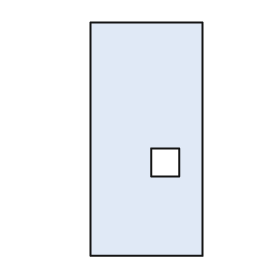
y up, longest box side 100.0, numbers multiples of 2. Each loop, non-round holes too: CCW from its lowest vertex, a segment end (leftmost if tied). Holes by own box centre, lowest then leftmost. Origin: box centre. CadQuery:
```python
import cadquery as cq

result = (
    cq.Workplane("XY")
    .moveTo(-24.0, -50.0)
    .lineTo(24.0, -50.0)
    .lineTo(24.0, 50.0)
    .lineTo(-24.0, 50.0)
    .close()
    .moveTo(2.0, -16.0)
    .lineTo(14.0, -16.0)
    .lineTo(14.0, -4.0)
    .lineTo(2.0, -4.0)
    .close()
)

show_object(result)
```